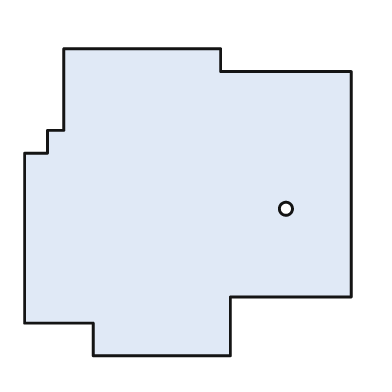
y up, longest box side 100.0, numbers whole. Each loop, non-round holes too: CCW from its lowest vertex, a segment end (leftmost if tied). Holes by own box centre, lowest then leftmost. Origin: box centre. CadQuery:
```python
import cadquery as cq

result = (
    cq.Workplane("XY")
    .moveTo(-29.0, -47.0)
    .lineTo(13.0, -47.0)
    .lineTo(13.0, -29.0)
    .lineTo(50.0, -29.0)
    .lineTo(50.0, 40.0)
    .lineTo(10.0, 40.0)
    .lineTo(10.0, 47.0)
    .lineTo(-38.0, 47.0)
    .lineTo(-38.0, 22.0)
    .lineTo(-43.0, 22.0)
    .lineTo(-43.0, 15.0)
    .lineTo(-50.0, 15.0)
    .lineTo(-50.0, -37.0)
    .lineTo(-29.0, -37.0)
    .close()
    .moveTo(30.0, -2.0)
    .circle(2.0)
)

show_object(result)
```